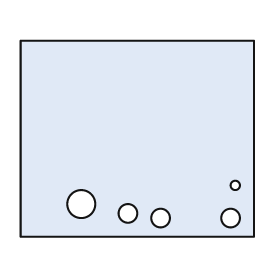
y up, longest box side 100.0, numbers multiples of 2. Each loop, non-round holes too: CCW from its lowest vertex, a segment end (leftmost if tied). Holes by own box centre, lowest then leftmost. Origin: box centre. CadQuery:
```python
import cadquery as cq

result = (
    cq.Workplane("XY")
    .moveTo(-50.0, -42.0)
    .lineTo(50.0, -42.0)
    .lineTo(50.0, 42.0)
    .lineTo(-50.0, 42.0)
    .close()
    .moveTo(10.0, -34.0)
    .circle(4.0)
    .moveTo(40.0, -34.0)
    .circle(4.0)
    .moveTo(-4.0, -32.0)
    .circle(4.0)
    .moveTo(-24.0, -28.0)
    .circle(6.0)
    .moveTo(42.0, -20.0)
    .circle(2.0)
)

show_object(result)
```